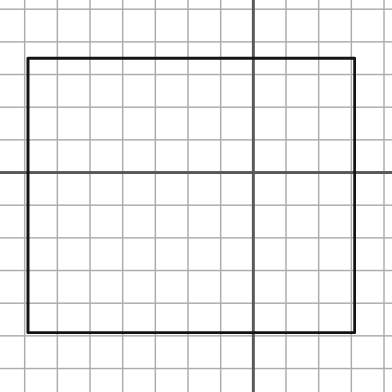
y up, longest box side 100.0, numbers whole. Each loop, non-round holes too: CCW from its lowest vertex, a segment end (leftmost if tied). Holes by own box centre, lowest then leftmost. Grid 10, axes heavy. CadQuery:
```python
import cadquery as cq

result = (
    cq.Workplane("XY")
    .moveTo(-69.0, -49.0)
    .lineTo(31.0, -49.0)
    .lineTo(31.0, 35.0)
    .lineTo(-69.0, 35.0)
    .close()
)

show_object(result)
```